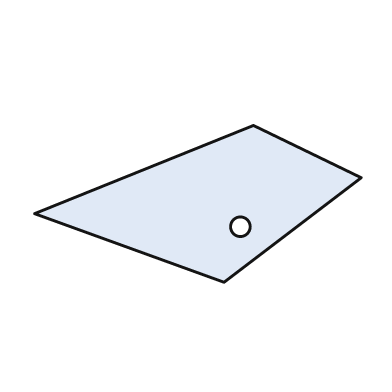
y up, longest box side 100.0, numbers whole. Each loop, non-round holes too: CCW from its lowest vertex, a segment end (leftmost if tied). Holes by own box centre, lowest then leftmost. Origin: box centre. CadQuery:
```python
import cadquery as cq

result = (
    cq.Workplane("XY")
    .moveTo(8.0, -24.0)
    .lineTo(50.0, 8.0)
    .lineTo(17.0, 24.0)
    .lineTo(-50.0, -3.0)
    .close()
    .moveTo(13.0, -7.0)
    .circle(3.0)
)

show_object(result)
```